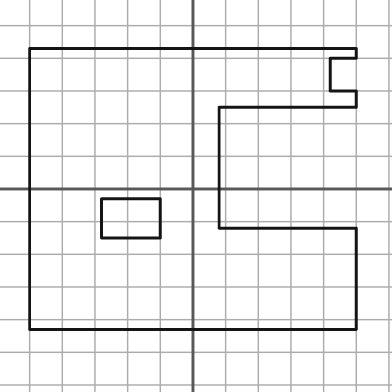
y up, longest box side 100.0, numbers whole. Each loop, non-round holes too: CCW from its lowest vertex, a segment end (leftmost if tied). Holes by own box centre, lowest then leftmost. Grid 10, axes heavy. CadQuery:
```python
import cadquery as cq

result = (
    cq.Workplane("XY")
    .moveTo(-50.0, -43.0)
    .lineTo(50.0, -43.0)
    .lineTo(50.0, -12.0)
    .lineTo(8.0, -12.0)
    .lineTo(8.0, 25.0)
    .lineTo(50.0, 25.0)
    .lineTo(50.0, 30.0)
    .lineTo(42.0, 30.0)
    .lineTo(42.0, 40.0)
    .lineTo(50.0, 40.0)
    .lineTo(50.0, 43.0)
    .lineTo(-50.0, 43.0)
    .close()
    .moveTo(-28.0, -15.0)
    .lineTo(-10.0, -15.0)
    .lineTo(-10.0, -3.0)
    .lineTo(-28.0, -3.0)
    .close()
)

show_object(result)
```